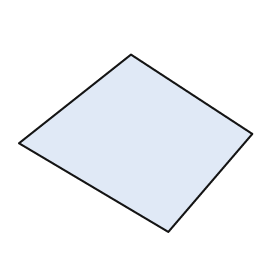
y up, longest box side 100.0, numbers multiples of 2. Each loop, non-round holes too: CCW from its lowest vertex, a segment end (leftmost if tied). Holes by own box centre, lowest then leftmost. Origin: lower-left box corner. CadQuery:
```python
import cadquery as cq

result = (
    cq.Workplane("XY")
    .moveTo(64.0, 0.0)
    .lineTo(100.0, 42.0)
    .lineTo(48.0, 76.0)
    .lineTo(0.0, 38.0)
    .close()
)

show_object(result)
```